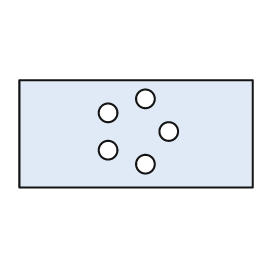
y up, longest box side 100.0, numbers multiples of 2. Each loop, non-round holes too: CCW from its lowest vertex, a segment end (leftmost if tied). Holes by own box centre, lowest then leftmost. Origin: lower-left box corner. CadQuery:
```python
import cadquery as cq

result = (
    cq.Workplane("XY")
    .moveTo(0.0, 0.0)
    .lineTo(100.0, 0.0)
    .lineTo(100.0, 46.0)
    .lineTo(0.0, 46.0)
    .close()
    .moveTo(54.0, 10.0)
    .circle(4.0)
    .moveTo(38.0, 16.0)
    .circle(4.0)
    .moveTo(64.0, 24.0)
    .circle(4.0)
    .moveTo(38.0, 32.0)
    .circle(4.0)
    .moveTo(54.0, 38.0)
    .circle(4.0)
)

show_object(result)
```